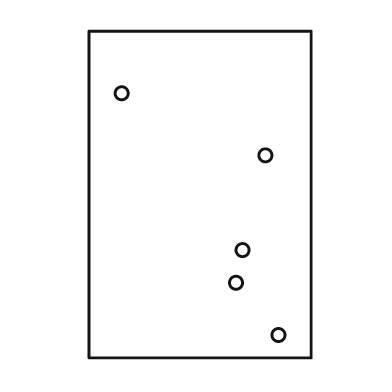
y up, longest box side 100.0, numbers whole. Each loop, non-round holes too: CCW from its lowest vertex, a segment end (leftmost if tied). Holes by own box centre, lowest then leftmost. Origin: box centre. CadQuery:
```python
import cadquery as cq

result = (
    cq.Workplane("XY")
    .moveTo(-34.0, -50.0)
    .lineTo(34.0, -50.0)
    .lineTo(34.0, 50.0)
    .lineTo(-34.0, 50.0)
    .close()
    .moveTo(24.0, -43.0)
    .circle(2.0)
    .moveTo(11.0, -27.0)
    .circle(2.0)
    .moveTo(13.0, -17.0)
    .circle(2.0)
    .moveTo(20.0, 12.0)
    .circle(2.0)
    .moveTo(-24.0, 31.0)
    .circle(2.0)
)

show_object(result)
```